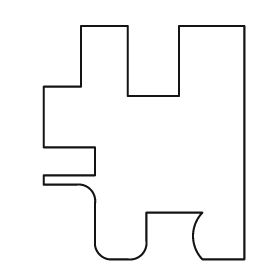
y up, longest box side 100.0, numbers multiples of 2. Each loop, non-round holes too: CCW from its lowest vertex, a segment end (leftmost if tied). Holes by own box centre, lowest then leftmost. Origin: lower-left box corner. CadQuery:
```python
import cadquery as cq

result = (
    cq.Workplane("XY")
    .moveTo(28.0, 0.0)
    .lineTo(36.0, 0.0)
    .threePointArc((42.0, 2.0), (44.0, 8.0))
    .lineTo(44.0, 20.0)
    .lineTo(68.0, 20.0)
    .threePointArc((64.0, 10.0), (68.0, 0.0))
    .lineTo(86.0, 0.0)
    .lineTo(86.0, 100.0)
    .lineTo(58.0, 100.0)
    .lineTo(58.0, 70.0)
    .lineTo(36.0, 70.0)
    .lineTo(36.0, 100.0)
    .lineTo(16.0, 100.0)
    .lineTo(16.0, 74.0)
    .lineTo(0.0, 74.0)
    .lineTo(0.0, 48.0)
    .lineTo(22.0, 48.0)
    .lineTo(22.0, 36.0)
    .lineTo(0.0, 36.0)
    .lineTo(0.0, 32.0)
    .lineTo(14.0, 32.0)
    .threePointArc((20.0, 30.0), (22.0, 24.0))
    .lineTo(22.0, 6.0)
    .threePointArc((24.0, 2.0), (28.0, 0.0))
    .close()
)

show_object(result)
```